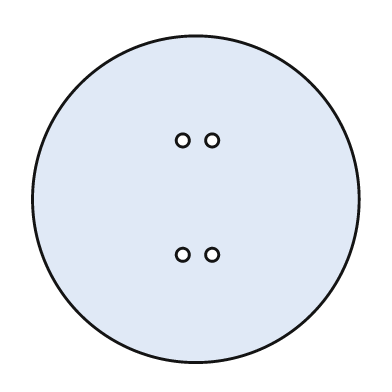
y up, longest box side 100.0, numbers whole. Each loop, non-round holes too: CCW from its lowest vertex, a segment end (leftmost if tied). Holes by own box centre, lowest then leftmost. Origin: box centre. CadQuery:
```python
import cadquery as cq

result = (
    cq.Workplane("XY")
    .moveTo(0.0, 0.0)
    .circle(50.0)
    .moveTo(-4.0, -17.0)
    .circle(2.0)
    .moveTo(5.0, -17.0)
    .circle(2.0)
    .moveTo(-4.0, 18.0)
    .circle(2.0)
    .moveTo(5.0, 18.0)
    .circle(2.0)
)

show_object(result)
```